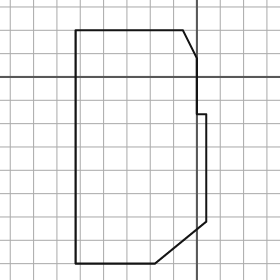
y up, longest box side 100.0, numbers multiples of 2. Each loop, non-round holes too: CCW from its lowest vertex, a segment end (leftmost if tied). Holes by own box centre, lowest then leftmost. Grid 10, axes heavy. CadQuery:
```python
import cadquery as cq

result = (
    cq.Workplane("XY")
    .moveTo(-52.0, -80.0)
    .lineTo(-18.0, -80.0)
    .lineTo(4.0, -62.0)
    .lineTo(4.0, -16.0)
    .lineTo(0.0, -16.0)
    .lineTo(0.0, 8.0)
    .lineTo(-6.0, 20.0)
    .lineTo(-52.0, 20.0)
    .close()
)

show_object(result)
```